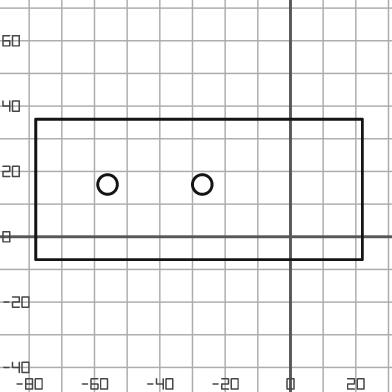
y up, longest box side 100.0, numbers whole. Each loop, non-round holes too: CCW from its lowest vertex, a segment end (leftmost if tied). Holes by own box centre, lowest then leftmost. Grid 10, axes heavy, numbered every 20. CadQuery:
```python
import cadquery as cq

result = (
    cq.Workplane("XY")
    .moveTo(-78.0, -7.0)
    .lineTo(22.0, -7.0)
    .lineTo(22.0, 36.0)
    .lineTo(-78.0, 36.0)
    .close()
    .moveTo(-56.0, 16.0)
    .circle(3.0)
    .moveTo(-27.0, 16.0)
    .circle(3.0)
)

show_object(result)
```